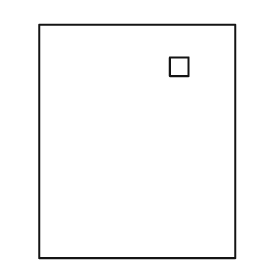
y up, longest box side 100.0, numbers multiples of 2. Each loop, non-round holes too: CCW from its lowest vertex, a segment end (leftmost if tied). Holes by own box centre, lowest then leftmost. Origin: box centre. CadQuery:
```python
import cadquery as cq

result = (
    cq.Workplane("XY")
    .moveTo(-42.0, -50.0)
    .lineTo(42.0, -50.0)
    .lineTo(42.0, 50.0)
    .lineTo(-42.0, 50.0)
    .close()
    .moveTo(14.0, 28.0)
    .lineTo(22.0, 28.0)
    .lineTo(22.0, 36.0)
    .lineTo(14.0, 36.0)
    .close()
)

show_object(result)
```